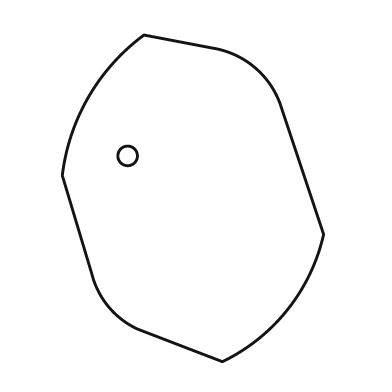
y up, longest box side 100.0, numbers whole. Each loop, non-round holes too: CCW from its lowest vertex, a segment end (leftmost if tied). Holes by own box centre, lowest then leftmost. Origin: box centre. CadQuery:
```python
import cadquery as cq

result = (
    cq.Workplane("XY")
    .moveTo(9.0, -50.0)
    .threePointArc((29.0, -34.0), (40.0, -11.0))
    .lineTo(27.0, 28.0)
    .threePointArc((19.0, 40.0), (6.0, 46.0))
    .lineTo(-15.0, 50.0)
    .threePointArc((-32.0, 31.0), (-40.0, 7.0))
    .lineTo(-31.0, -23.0)
    .threePointArc((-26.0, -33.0), (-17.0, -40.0))
    .close()
    .moveTo(-20.0, 13.0)
    .circle(3.0)
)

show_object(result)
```